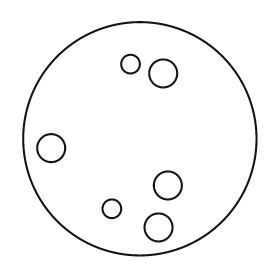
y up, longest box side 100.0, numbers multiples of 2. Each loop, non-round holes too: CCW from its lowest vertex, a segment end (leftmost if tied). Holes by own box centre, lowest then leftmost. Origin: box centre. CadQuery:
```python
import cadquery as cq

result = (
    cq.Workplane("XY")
    .moveTo(0.0, 0.0)
    .circle(50.0)
    .moveTo(8.0, -38.0)
    .circle(6.0)
    .moveTo(-12.0, -30.0)
    .circle(4.0)
    .moveTo(12.0, -20.0)
    .circle(6.0)
    .moveTo(-38.0, -4.0)
    .circle(6.0)
    .moveTo(10.0, 28.0)
    .circle(6.0)
    .moveTo(-4.0, 32.0)
    .circle(4.0)
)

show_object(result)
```